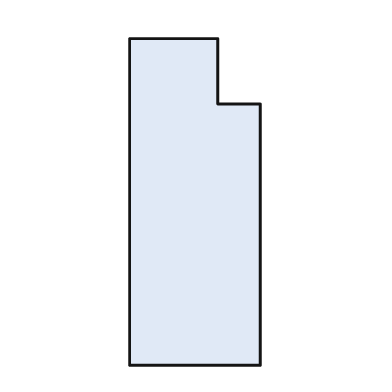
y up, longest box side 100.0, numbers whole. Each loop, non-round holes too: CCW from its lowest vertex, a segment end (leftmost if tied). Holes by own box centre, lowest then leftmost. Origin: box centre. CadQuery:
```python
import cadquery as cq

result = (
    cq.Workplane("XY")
    .moveTo(-20.0, -50.0)
    .lineTo(20.0, -50.0)
    .lineTo(20.0, 30.0)
    .lineTo(7.0, 30.0)
    .lineTo(7.0, 50.0)
    .lineTo(-20.0, 50.0)
    .close()
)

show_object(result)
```